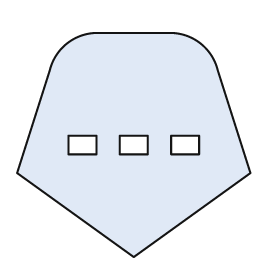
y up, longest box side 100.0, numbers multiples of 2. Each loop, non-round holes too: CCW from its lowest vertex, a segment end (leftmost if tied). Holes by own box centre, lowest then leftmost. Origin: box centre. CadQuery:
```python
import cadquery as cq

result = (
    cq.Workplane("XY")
    .moveTo(0.0, -48.0)
    .lineTo(50.0, -12.0)
    .lineTo(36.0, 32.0)
    .threePointArc((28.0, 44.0), (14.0, 48.0))
    .lineTo(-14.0, 48.0)
    .threePointArc((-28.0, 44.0), (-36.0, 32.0))
    .lineTo(-50.0, -12.0)
    .close()
    .moveTo(-28.0, -4.0)
    .lineTo(-16.0, -4.0)
    .lineTo(-16.0, 4.0)
    .lineTo(-28.0, 4.0)
    .close()
    .moveTo(-6.0, -4.0)
    .lineTo(6.0, -4.0)
    .lineTo(6.0, 4.0)
    .lineTo(-6.0, 4.0)
    .close()
    .moveTo(16.0, -4.0)
    .lineTo(28.0, -4.0)
    .lineTo(28.0, 4.0)
    .lineTo(16.0, 4.0)
    .close()
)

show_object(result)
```